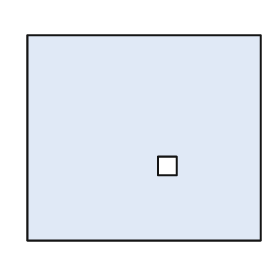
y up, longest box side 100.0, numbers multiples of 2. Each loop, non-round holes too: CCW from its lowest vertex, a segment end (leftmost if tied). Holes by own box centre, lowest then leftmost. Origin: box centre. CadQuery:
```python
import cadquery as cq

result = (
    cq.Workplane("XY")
    .moveTo(-50.0, -44.0)
    .lineTo(50.0, -44.0)
    .lineTo(50.0, 44.0)
    .lineTo(-50.0, 44.0)
    .close()
    .moveTo(6.0, -16.0)
    .lineTo(14.0, -16.0)
    .lineTo(14.0, -8.0)
    .lineTo(6.0, -8.0)
    .close()
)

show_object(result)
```